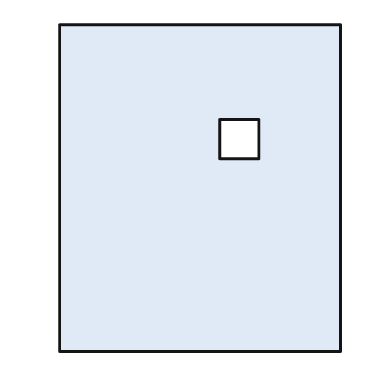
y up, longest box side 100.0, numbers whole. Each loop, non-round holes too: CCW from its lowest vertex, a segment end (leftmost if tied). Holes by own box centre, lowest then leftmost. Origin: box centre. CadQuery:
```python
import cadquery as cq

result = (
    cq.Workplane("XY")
    .moveTo(-43.0, -50.0)
    .lineTo(43.0, -50.0)
    .lineTo(43.0, 50.0)
    .lineTo(-43.0, 50.0)
    .close()
    .moveTo(6.0, 9.0)
    .lineTo(18.0, 9.0)
    .lineTo(18.0, 21.0)
    .lineTo(6.0, 21.0)
    .close()
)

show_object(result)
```